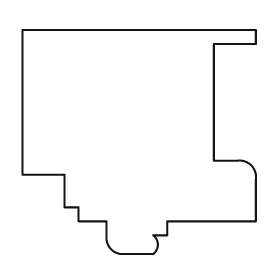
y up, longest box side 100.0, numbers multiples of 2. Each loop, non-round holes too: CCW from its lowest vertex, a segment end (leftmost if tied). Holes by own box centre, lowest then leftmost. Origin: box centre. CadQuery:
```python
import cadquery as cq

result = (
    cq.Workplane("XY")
    .moveTo(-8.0, -48.0)
    .lineTo(6.0, -48.0)
    .threePointArc((8.0, -44.0), (6.0, -40.0))
    .lineTo(12.0, -40.0)
    .lineTo(12.0, -34.0)
    .lineTo(50.0, -34.0)
    .lineTo(50.0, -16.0)
    .threePointArc((48.0, -10.0), (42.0, -8.0))
    .lineTo(32.0, -8.0)
    .lineTo(32.0, 42.0)
    .lineTo(50.0, 42.0)
    .lineTo(50.0, 48.0)
    .lineTo(-50.0, 48.0)
    .lineTo(-50.0, -14.0)
    .lineTo(-32.0, -14.0)
    .lineTo(-32.0, -28.0)
    .lineTo(-26.0, -28.0)
    .lineTo(-26.0, -34.0)
    .lineTo(-14.0, -34.0)
    .lineTo(-14.0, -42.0)
    .threePointArc((-12.0, -46.0), (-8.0, -48.0))
    .close()
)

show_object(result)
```